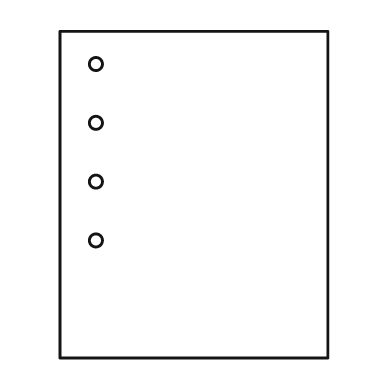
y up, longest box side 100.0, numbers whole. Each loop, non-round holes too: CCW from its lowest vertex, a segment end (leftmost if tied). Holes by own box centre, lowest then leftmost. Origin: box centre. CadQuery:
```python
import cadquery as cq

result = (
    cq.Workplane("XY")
    .moveTo(-41.0, -50.0)
    .lineTo(41.0, -50.0)
    .lineTo(41.0, 50.0)
    .lineTo(-41.0, 50.0)
    .close()
    .moveTo(-30.0, -14.0)
    .circle(2.0)
    .moveTo(-30.0, 4.0)
    .circle(2.0)
    .moveTo(-30.0, 22.0)
    .circle(2.0)
    .moveTo(-30.0, 40.0)
    .circle(2.0)
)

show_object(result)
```